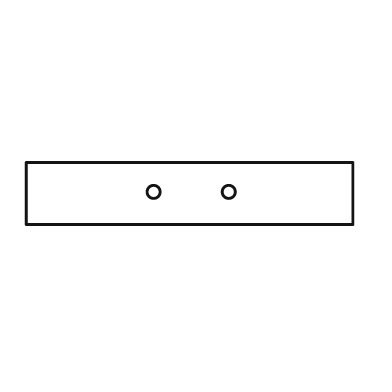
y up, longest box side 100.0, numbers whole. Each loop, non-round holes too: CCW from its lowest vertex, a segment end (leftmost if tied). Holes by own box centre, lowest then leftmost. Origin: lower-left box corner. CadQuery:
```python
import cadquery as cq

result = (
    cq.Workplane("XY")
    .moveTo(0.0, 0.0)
    .lineTo(100.0, 0.0)
    .lineTo(100.0, 19.0)
    .lineTo(0.0, 19.0)
    .close()
    .moveTo(39.0, 10.0)
    .circle(2.0)
    .moveTo(62.0, 10.0)
    .circle(2.0)
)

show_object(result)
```